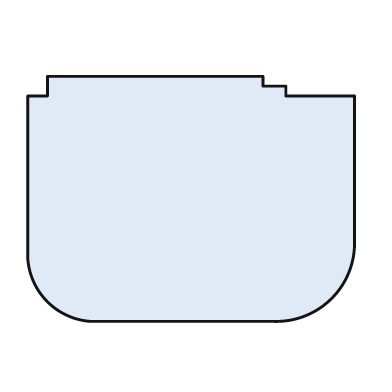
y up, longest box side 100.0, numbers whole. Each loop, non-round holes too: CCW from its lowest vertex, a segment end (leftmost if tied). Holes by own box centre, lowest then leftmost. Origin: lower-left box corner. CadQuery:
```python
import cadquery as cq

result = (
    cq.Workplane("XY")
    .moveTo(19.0, 0.0)
    .lineTo(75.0, 0.0)
    .threePointArc((93.0, 7.0), (100.0, 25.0))
    .lineTo(100.0, 69.0)
    .lineTo(79.0, 69.0)
    .lineTo(79.0, 72.0)
    .lineTo(72.0, 72.0)
    .lineTo(72.0, 75.0)
    .lineTo(6.0, 75.0)
    .lineTo(6.0, 69.0)
    .lineTo(0.0, 69.0)
    .lineTo(0.0, 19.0)
    .threePointArc((6.0, 6.0), (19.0, 0.0))
    .close()
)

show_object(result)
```